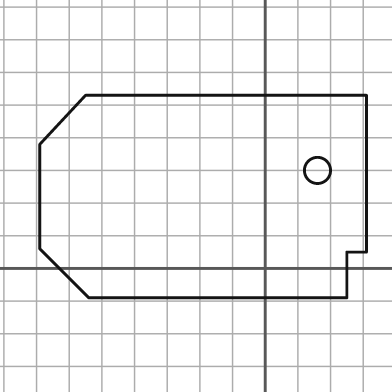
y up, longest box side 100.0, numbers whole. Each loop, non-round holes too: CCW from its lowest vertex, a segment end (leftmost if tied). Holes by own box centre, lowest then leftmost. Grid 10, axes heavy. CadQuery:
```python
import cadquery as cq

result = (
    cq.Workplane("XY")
    .moveTo(-54.0, -9.0)
    .lineTo(25.0, -9.0)
    .lineTo(25.0, 5.0)
    .lineTo(31.0, 5.0)
    .lineTo(31.0, 53.0)
    .lineTo(-55.0, 53.0)
    .lineTo(-69.0, 38.0)
    .lineTo(-69.0, 6.0)
    .close()
    .moveTo(16.0, 30.0)
    .circle(4.0)
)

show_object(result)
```